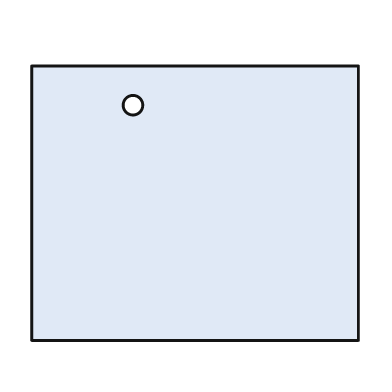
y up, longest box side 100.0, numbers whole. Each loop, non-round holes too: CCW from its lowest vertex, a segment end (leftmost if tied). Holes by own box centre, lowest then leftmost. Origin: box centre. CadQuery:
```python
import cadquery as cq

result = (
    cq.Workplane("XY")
    .moveTo(-50.0, -42.0)
    .lineTo(50.0, -42.0)
    .lineTo(50.0, 42.0)
    .lineTo(-50.0, 42.0)
    .close()
    .moveTo(-19.0, 30.0)
    .circle(3.0)
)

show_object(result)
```